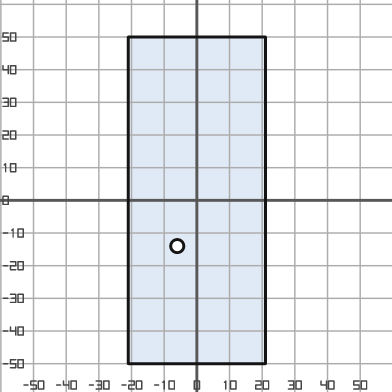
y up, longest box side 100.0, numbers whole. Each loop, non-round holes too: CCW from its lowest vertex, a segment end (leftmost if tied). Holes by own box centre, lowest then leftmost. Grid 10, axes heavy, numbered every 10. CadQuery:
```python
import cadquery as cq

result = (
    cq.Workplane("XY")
    .moveTo(-21.0, -50.0)
    .lineTo(21.0, -50.0)
    .lineTo(21.0, 50.0)
    .lineTo(-21.0, 50.0)
    .close()
    .moveTo(-6.0, -14.0)
    .circle(2.0)
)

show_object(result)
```